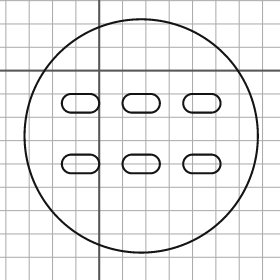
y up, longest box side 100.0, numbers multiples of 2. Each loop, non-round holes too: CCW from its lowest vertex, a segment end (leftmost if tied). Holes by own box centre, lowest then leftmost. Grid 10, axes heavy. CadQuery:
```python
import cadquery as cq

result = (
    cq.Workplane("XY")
    .moveTo(18.0, -28.0)
    .circle(50.0)
    .moveTo(-12.0, -44.0)
    .lineTo(-4.0, -44.0)
    .threePointArc((0.0, -40.0), (-4.0, -36.0))
    .lineTo(-12.0, -36.0)
    .threePointArc((-16.0, -40.0), (-12.0, -44.0))
    .close()
    .moveTo(14.0, -44.0)
    .lineTo(22.0, -44.0)
    .threePointArc((26.0, -40.0), (22.0, -36.0))
    .lineTo(14.0, -36.0)
    .threePointArc((10.0, -40.0), (14.0, -44.0))
    .close()
    .moveTo(40.0, -44.0)
    .lineTo(48.0, -44.0)
    .threePointArc((52.0, -40.0), (48.0, -36.0))
    .lineTo(40.0, -36.0)
    .threePointArc((36.0, -40.0), (40.0, -44.0))
    .close()
    .moveTo(-12.0, -18.0)
    .lineTo(-4.0, -18.0)
    .threePointArc((0.0, -14.0), (-4.0, -10.0))
    .lineTo(-12.0, -10.0)
    .threePointArc((-16.0, -14.0), (-12.0, -18.0))
    .close()
    .moveTo(14.0, -18.0)
    .lineTo(22.0, -18.0)
    .threePointArc((26.0, -14.0), (22.0, -10.0))
    .lineTo(14.0, -10.0)
    .threePointArc((10.0, -14.0), (14.0, -18.0))
    .close()
    .moveTo(40.0, -18.0)
    .lineTo(48.0, -18.0)
    .threePointArc((52.0, -14.0), (48.0, -10.0))
    .lineTo(40.0, -10.0)
    .threePointArc((36.0, -14.0), (40.0, -18.0))
    .close()
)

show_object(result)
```